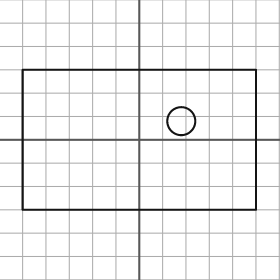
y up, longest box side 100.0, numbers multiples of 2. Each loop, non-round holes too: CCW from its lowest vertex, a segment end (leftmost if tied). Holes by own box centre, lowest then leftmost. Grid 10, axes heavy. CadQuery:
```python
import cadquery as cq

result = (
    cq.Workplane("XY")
    .moveTo(-50.0, -30.0)
    .lineTo(50.0, -30.0)
    .lineTo(50.0, 30.0)
    .lineTo(-50.0, 30.0)
    .close()
    .moveTo(18.0, 8.0)
    .circle(6.0)
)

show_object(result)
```